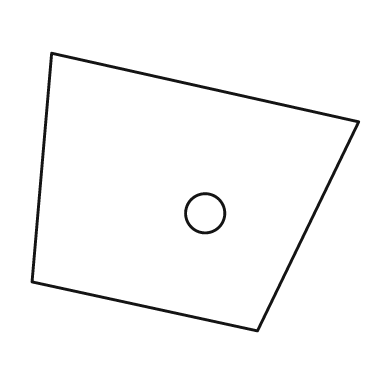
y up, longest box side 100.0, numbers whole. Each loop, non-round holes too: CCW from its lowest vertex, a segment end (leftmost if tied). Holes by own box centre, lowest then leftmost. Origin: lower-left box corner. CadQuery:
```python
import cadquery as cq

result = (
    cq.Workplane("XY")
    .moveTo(69.0, 0.0)
    .lineTo(100.0, 64.0)
    .lineTo(6.0, 85.0)
    .lineTo(0.0, 15.0)
    .close()
    .moveTo(53.0, 36.0)
    .circle(6.0)
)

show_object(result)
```